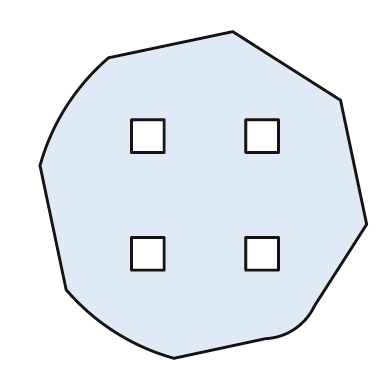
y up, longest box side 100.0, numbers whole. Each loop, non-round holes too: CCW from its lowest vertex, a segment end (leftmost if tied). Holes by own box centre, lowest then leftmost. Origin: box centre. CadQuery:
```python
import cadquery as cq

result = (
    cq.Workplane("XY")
    .moveTo(-9.0, -50.0)
    .lineTo(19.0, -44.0)
    .threePointArc((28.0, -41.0), (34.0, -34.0))
    .lineTo(50.0, -9.0)
    .lineTo(42.0, 29.0)
    .lineTo(9.0, 50.0)
    .lineTo(-29.0, 42.0)
    .threePointArc((-42.0, 27.0), (-50.0, 9.0))
    .lineTo(-42.0, -29.0)
    .threePointArc((-27.0, -42.0), (-9.0, -50.0))
    .close()
    .moveTo(-22.0, -23.0)
    .lineTo(-12.0, -23.0)
    .lineTo(-12.0, -13.0)
    .lineTo(-22.0, -13.0)
    .close()
    .moveTo(13.0, -23.0)
    .lineTo(23.0, -23.0)
    .lineTo(23.0, -13.0)
    .lineTo(13.0, -13.0)
    .close()
    .moveTo(-22.0, 13.0)
    .lineTo(-12.0, 13.0)
    .lineTo(-12.0, 23.0)
    .lineTo(-22.0, 23.0)
    .close()
    .moveTo(13.0, 13.0)
    .lineTo(23.0, 13.0)
    .lineTo(23.0, 23.0)
    .lineTo(13.0, 23.0)
    .close()
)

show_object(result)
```